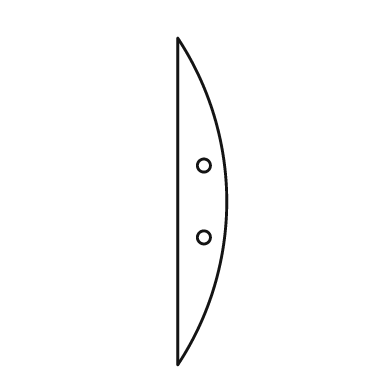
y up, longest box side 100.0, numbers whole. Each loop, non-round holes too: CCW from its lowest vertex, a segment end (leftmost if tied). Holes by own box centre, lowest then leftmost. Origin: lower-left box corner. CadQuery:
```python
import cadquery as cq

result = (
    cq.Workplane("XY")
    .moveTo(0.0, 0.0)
    .threePointArc((15.0, 50.0), (0.0, 100.0))
    .close()
    .moveTo(8.0, 39.0)
    .circle(2.0)
    .moveTo(8.0, 61.0)
    .circle(2.0)
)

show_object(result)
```